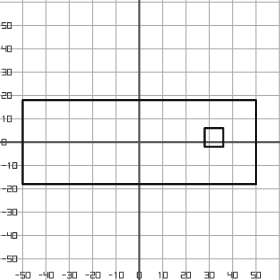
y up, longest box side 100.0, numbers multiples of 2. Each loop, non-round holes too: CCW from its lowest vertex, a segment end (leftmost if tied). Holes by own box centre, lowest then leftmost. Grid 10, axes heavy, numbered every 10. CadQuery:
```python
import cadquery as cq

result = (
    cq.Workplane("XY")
    .moveTo(-50.0, -18.0)
    .lineTo(50.0, -18.0)
    .lineTo(50.0, 18.0)
    .lineTo(-50.0, 18.0)
    .close()
    .moveTo(28.0, -2.0)
    .lineTo(36.0, -2.0)
    .lineTo(36.0, 6.0)
    .lineTo(28.0, 6.0)
    .close()
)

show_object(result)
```